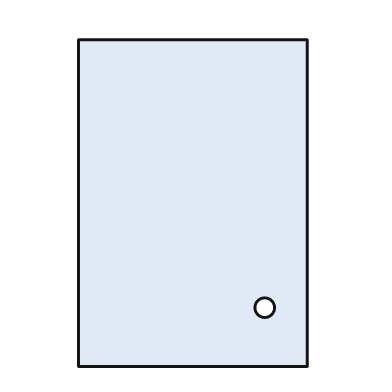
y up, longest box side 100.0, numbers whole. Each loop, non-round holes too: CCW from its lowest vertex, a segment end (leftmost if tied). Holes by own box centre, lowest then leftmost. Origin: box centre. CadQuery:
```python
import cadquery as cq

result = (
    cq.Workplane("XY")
    .moveTo(-35.0, -50.0)
    .lineTo(35.0, -50.0)
    .lineTo(35.0, 50.0)
    .lineTo(-35.0, 50.0)
    .close()
    .moveTo(22.0, -32.0)
    .circle(3.0)
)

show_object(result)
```